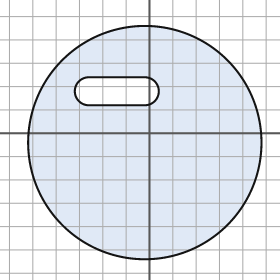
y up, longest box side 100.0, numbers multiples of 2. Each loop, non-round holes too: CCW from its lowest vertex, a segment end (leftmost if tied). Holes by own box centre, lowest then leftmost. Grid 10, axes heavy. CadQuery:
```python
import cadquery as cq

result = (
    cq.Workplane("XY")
    .moveTo(-2.0, -4.0)
    .circle(50.0)
    .moveTo(-26.0, 12.0)
    .lineTo(-2.0, 12.0)
    .threePointArc((4.0, 18.0), (-2.0, 24.0))
    .lineTo(-26.0, 24.0)
    .threePointArc((-32.0, 18.0), (-26.0, 12.0))
    .close()
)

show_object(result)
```